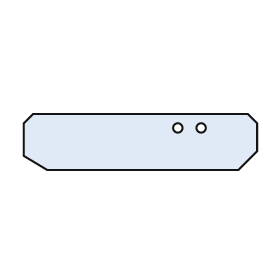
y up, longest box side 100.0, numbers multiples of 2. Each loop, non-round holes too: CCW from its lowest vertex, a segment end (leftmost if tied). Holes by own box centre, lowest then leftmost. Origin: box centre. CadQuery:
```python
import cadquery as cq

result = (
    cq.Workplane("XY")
    .moveTo(-40.0, -12.0)
    .lineTo(42.0, -12.0)
    .lineTo(50.0, -4.0)
    .lineTo(50.0, 8.0)
    .lineTo(46.0, 12.0)
    .lineTo(-46.0, 12.0)
    .lineTo(-50.0, 8.0)
    .lineTo(-50.0, -6.0)
    .close()
    .moveTo(16.0, 6.0)
    .circle(2.0)
    .moveTo(26.0, 6.0)
    .circle(2.0)
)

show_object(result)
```